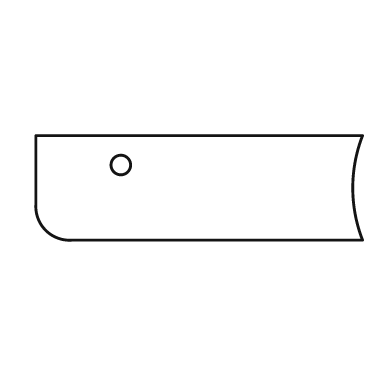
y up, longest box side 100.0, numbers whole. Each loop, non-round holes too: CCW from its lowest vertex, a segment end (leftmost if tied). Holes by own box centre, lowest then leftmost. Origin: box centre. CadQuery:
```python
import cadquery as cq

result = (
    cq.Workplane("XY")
    .moveTo(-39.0, -16.0)
    .lineTo(50.0, -16.0)
    .threePointArc((47.0, 0.0), (50.0, 16.0))
    .lineTo(-50.0, 16.0)
    .lineTo(-50.0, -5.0)
    .threePointArc((-47.0, -13.0), (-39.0, -16.0))
    .close()
    .moveTo(-24.0, 7.0)
    .circle(3.0)
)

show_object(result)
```